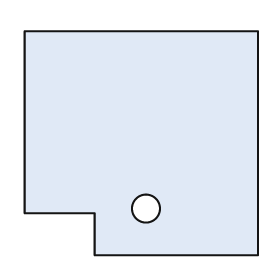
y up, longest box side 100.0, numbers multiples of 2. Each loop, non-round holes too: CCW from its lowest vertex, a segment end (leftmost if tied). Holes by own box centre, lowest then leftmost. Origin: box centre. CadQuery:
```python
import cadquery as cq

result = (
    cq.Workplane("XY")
    .moveTo(-20.0, -48.0)
    .lineTo(50.0, -48.0)
    .lineTo(50.0, 48.0)
    .lineTo(-50.0, 48.0)
    .lineTo(-50.0, -30.0)
    .lineTo(-20.0, -30.0)
    .close()
    .moveTo(2.0, -28.0)
    .circle(6.0)
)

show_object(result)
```